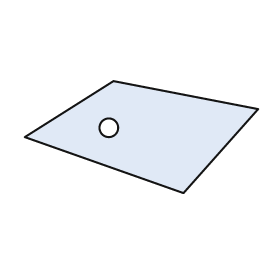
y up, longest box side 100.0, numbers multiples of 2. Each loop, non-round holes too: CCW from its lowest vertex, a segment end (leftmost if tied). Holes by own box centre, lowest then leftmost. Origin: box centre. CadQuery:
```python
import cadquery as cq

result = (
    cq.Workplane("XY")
    .moveTo(18.0, -24.0)
    .lineTo(50.0, 12.0)
    .lineTo(-12.0, 24.0)
    .lineTo(-50.0, 0.0)
    .close()
    .moveTo(-14.0, 4.0)
    .circle(4.0)
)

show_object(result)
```